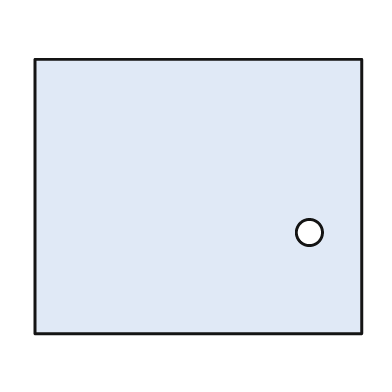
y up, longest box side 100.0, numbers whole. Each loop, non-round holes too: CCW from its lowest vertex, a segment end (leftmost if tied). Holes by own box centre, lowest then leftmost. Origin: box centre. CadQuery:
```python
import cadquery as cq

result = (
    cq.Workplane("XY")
    .moveTo(-50.0, -42.0)
    .lineTo(50.0, -42.0)
    .lineTo(50.0, 42.0)
    .lineTo(-50.0, 42.0)
    .close()
    .moveTo(34.0, -11.0)
    .circle(4.0)
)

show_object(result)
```